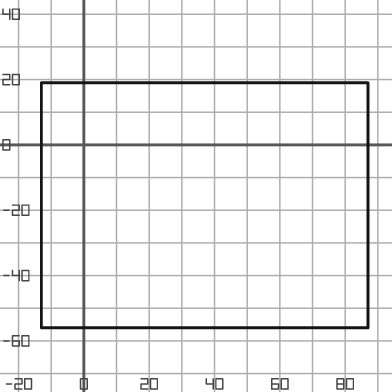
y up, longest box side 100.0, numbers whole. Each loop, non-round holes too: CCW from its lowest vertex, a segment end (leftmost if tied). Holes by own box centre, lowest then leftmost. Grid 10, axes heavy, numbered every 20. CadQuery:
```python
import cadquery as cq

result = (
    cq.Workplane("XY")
    .moveTo(-13.0, -56.0)
    .lineTo(87.0, -56.0)
    .lineTo(87.0, 19.0)
    .lineTo(-13.0, 19.0)
    .close()
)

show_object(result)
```